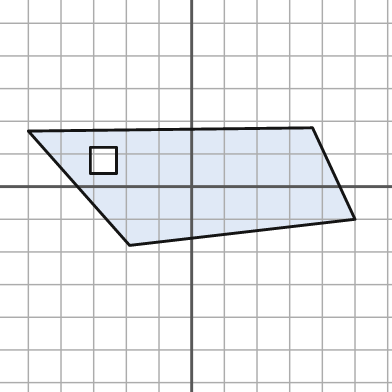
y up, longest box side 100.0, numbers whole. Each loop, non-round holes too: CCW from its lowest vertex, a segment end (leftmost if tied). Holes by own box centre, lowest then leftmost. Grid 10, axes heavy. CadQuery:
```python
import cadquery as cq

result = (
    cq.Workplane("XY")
    .moveTo(-19.0, -18.0)
    .lineTo(50.0, -10.0)
    .lineTo(37.0, 18.0)
    .lineTo(-50.0, 17.0)
    .close()
    .moveTo(-31.0, 4.0)
    .lineTo(-23.0, 4.0)
    .lineTo(-23.0, 12.0)
    .lineTo(-31.0, 12.0)
    .close()
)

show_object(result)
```